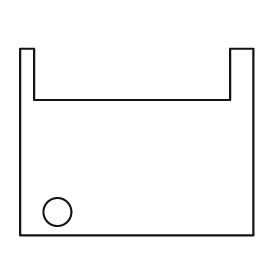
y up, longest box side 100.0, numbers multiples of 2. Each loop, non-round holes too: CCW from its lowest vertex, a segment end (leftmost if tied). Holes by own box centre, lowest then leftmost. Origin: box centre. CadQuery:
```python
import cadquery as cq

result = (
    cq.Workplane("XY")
    .moveTo(-50.0, -40.0)
    .lineTo(50.0, -40.0)
    .lineTo(50.0, 40.0)
    .lineTo(40.0, 40.0)
    .lineTo(40.0, 18.0)
    .lineTo(-44.0, 18.0)
    .lineTo(-44.0, 40.0)
    .lineTo(-50.0, 40.0)
    .close()
    .moveTo(-34.0, -30.0)
    .circle(6.0)
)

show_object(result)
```